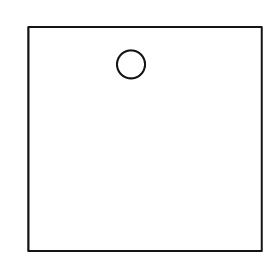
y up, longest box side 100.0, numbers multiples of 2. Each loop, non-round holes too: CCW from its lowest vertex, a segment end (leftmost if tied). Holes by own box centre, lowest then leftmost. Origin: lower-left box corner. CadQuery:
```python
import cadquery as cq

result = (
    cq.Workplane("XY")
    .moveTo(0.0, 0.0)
    .lineTo(100.0, 0.0)
    .lineTo(100.0, 96.0)
    .lineTo(0.0, 96.0)
    .close()
    .moveTo(44.0, 80.0)
    .circle(6.0)
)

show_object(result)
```